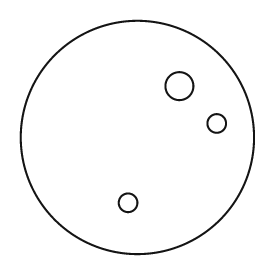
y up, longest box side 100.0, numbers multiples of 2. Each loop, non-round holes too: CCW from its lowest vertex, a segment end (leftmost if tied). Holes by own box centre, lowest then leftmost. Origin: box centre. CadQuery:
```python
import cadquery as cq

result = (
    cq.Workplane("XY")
    .moveTo(0.0, 0.0)
    .circle(50.0)
    .moveTo(-4.0, -28.0)
    .circle(4.0)
    .moveTo(34.0, 6.0)
    .circle(4.0)
    .moveTo(18.0, 22.0)
    .circle(6.0)
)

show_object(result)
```